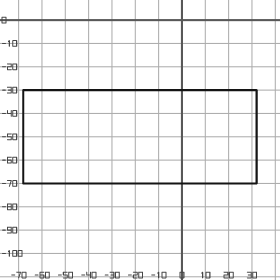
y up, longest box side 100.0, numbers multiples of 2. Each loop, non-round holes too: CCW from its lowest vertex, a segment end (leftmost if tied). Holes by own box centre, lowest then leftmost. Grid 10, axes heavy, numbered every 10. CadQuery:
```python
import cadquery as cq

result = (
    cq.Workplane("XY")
    .moveTo(-68.0, -70.0)
    .lineTo(32.0, -70.0)
    .lineTo(32.0, -30.0)
    .lineTo(-68.0, -30.0)
    .close()
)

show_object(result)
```